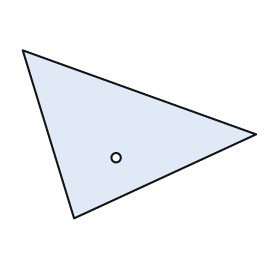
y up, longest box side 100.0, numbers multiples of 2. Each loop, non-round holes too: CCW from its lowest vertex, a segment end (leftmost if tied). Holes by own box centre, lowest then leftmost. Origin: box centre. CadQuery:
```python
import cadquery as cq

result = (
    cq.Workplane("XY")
    .moveTo(-28.0, -36.0)
    .lineTo(50.0, 0.0)
    .lineTo(-50.0, 36.0)
    .close()
    .moveTo(-10.0, -10.0)
    .circle(2.0)
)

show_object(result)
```